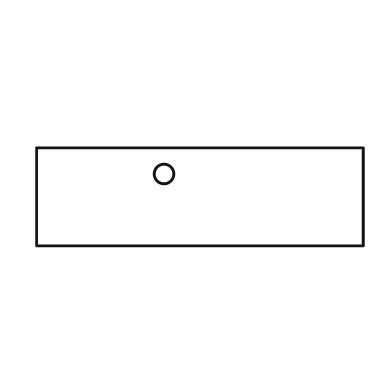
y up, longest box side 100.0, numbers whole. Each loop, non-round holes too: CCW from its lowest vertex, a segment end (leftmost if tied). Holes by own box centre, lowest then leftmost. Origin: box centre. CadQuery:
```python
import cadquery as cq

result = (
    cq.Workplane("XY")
    .moveTo(-50.0, -15.0)
    .lineTo(50.0, -15.0)
    .lineTo(50.0, 15.0)
    .lineTo(-50.0, 15.0)
    .close()
    .moveTo(-11.0, 7.0)
    .circle(3.0)
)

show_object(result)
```